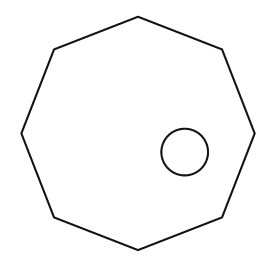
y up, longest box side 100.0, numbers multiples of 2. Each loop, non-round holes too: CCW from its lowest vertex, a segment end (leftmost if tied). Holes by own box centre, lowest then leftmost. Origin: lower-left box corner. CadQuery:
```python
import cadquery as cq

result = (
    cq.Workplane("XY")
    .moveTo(50.0, 0.0)
    .lineTo(86.0, 14.0)
    .lineTo(100.0, 50.0)
    .lineTo(86.0, 86.0)
    .lineTo(50.0, 100.0)
    .lineTo(14.0, 86.0)
    .lineTo(0.0, 50.0)
    .lineTo(14.0, 14.0)
    .close()
    .moveTo(70.0, 42.0)
    .circle(10.0)
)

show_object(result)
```